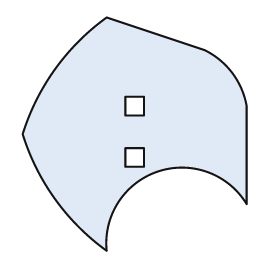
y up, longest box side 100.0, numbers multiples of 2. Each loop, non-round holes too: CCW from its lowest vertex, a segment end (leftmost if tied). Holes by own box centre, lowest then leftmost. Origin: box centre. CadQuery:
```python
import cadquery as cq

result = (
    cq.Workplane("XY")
    .moveTo(-12.0, -50.0)
    .threePointArc((10.0, -16.0), (48.0, -30.0))
    .lineTo(48.0, 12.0)
    .threePointArc((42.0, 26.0), (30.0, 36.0))
    .lineTo(-12.0, 50.0)
    .threePointArc((-34.0, 28.0), (-48.0, 0.0))
    .threePointArc((-34.0, -28.0), (-12.0, -50.0))
    .close()
    .moveTo(-4.0, -14.0)
    .lineTo(4.0, -14.0)
    .lineTo(4.0, -6.0)
    .lineTo(-4.0, -6.0)
    .close()
    .moveTo(-4.0, 8.0)
    .lineTo(4.0, 8.0)
    .lineTo(4.0, 16.0)
    .lineTo(-4.0, 16.0)
    .close()
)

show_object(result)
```